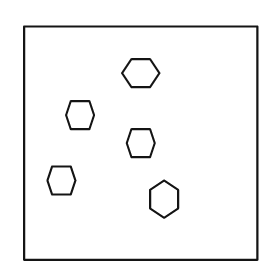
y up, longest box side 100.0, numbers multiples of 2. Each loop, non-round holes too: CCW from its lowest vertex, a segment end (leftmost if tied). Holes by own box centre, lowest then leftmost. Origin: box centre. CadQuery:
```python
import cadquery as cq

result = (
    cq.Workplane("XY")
    .moveTo(-50.0, -50.0)
    .lineTo(50.0, -50.0)
    .lineTo(50.0, 50.0)
    .lineTo(-50.0, 50.0)
    .close()
    .moveTo(10.0, -32.0)
    .lineTo(16.0, -28.0)
    .lineTo(16.0, -20.0)
    .lineTo(10.0, -16.0)
    .lineTo(4.0, -20.0)
    .lineTo(4.0, -28.0)
    .close()
    .moveTo(-38.0, -22.0)
    .lineTo(-30.0, -22.0)
    .lineTo(-28.0, -16.0)
    .lineTo(-30.0, -10.0)
    .lineTo(-38.0, -10.0)
    .lineTo(-40.0, -16.0)
    .close()
    .moveTo(-4.0, -6.0)
    .lineTo(4.0, -6.0)
    .lineTo(6.0, 0.0)
    .lineTo(4.0, 6.0)
    .lineTo(-4.0, 6.0)
    .lineTo(-6.0, 0.0)
    .close()
    .moveTo(-30.0, 6.0)
    .lineTo(-22.0, 6.0)
    .lineTo(-20.0, 12.0)
    .lineTo(-22.0, 18.0)
    .lineTo(-30.0, 18.0)
    .lineTo(-32.0, 12.0)
    .close()
    .moveTo(-4.0, 24.0)
    .lineTo(4.0, 24.0)
    .lineTo(8.0, 30.0)
    .lineTo(4.0, 36.0)
    .lineTo(-4.0, 36.0)
    .lineTo(-8.0, 30.0)
    .close()
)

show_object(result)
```